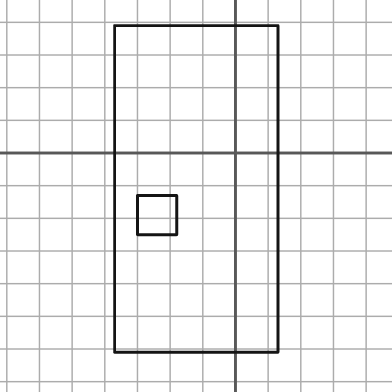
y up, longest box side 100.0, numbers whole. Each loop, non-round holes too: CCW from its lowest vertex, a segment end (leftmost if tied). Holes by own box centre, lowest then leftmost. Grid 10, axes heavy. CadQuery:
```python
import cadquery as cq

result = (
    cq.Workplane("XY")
    .moveTo(-37.0, -61.0)
    .lineTo(13.0, -61.0)
    .lineTo(13.0, 39.0)
    .lineTo(-37.0, 39.0)
    .close()
    .moveTo(-30.0, -25.0)
    .lineTo(-18.0, -25.0)
    .lineTo(-18.0, -13.0)
    .lineTo(-30.0, -13.0)
    .close()
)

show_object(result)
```